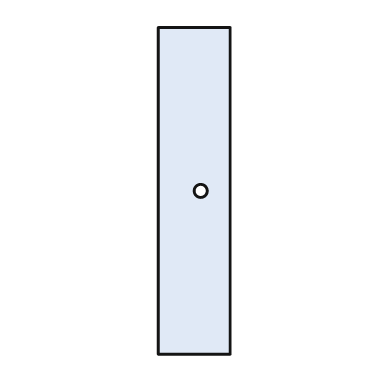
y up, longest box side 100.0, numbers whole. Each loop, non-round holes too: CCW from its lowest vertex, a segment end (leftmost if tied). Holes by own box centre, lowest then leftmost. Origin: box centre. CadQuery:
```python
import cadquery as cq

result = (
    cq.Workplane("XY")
    .moveTo(-11.0, -50.0)
    .lineTo(11.0, -50.0)
    .lineTo(11.0, 50.0)
    .lineTo(-11.0, 50.0)
    .close()
    .moveTo(2.0, 0.0)
    .circle(2.0)
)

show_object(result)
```